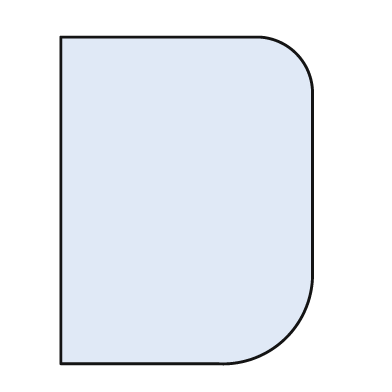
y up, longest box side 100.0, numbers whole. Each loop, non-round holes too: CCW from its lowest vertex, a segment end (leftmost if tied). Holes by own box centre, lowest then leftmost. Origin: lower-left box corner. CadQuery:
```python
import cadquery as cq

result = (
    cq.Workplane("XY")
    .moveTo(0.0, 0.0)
    .lineTo(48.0, 0.0)
    .threePointArc((69.0, 8.0), (77.0, 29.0))
    .lineTo(77.0, 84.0)
    .threePointArc((72.0, 95.0), (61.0, 100.0))
    .lineTo(0.0, 100.0)
    .close()
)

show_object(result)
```